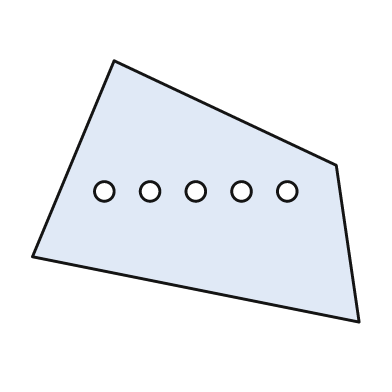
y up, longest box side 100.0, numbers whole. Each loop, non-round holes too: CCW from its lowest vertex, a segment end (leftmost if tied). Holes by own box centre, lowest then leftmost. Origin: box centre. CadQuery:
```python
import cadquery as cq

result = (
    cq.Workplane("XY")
    .moveTo(50.0, -40.0)
    .lineTo(43.0, 8.0)
    .lineTo(-25.0, 40.0)
    .lineTo(-50.0, -20.0)
    .close()
    .moveTo(-28.0, 0.0)
    .circle(3.0)
    .moveTo(-14.0, 0.0)
    .circle(3.0)
    .moveTo(0.0, 0.0)
    .circle(3.0)
    .moveTo(14.0, 0.0)
    .circle(3.0)
    .moveTo(28.0, 0.0)
    .circle(3.0)
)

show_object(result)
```